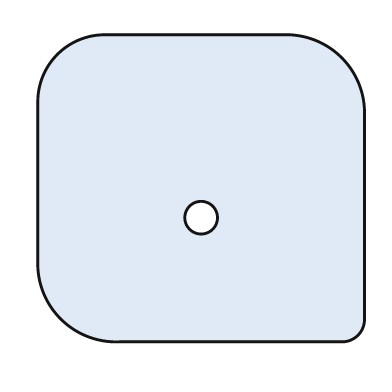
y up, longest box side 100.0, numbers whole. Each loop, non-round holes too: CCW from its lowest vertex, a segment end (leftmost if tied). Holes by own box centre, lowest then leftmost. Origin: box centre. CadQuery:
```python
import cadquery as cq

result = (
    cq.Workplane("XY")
    .moveTo(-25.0, -47.0)
    .lineTo(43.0, -47.0)
    .threePointArc((48.0, -45.0), (50.0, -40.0))
    .lineTo(50.0, 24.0)
    .threePointArc((43.0, 40.0), (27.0, 47.0))
    .lineTo(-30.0, 47.0)
    .threePointArc((-44.0, 41.0), (-50.0, 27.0))
    .lineTo(-50.0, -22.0)
    .threePointArc((-43.0, -40.0), (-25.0, -47.0))
    .close()
    .moveTo(0.0, -9.0)
    .circle(5.0)
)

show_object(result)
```